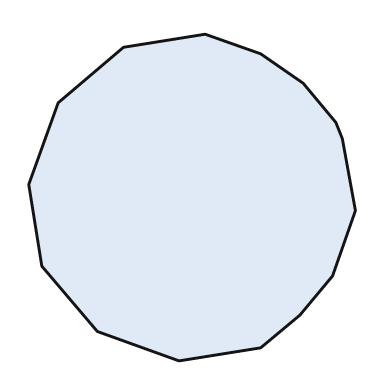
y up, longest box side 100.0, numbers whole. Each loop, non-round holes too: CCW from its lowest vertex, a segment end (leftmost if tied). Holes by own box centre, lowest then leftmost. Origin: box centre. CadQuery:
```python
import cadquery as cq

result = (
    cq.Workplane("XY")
    .moveTo(-4.0, -50.0)
    .lineTo(21.0, -46.0)
    .lineTo(33.0, -36.0)
    .lineTo(43.0, -24.0)
    .lineTo(50.0, -4.0)
    .lineTo(46.0, 18.0)
    .lineTo(44.0, 23.0)
    .lineTo(34.0, 35.0)
    .lineTo(21.0, 44.0)
    .lineTo(4.0, 50.0)
    .lineTo(-21.0, 46.0)
    .lineTo(-41.0, 29.0)
    .lineTo(-50.0, 4.0)
    .lineTo(-46.0, -21.0)
    .lineTo(-29.0, -41.0)
    .close()
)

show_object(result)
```